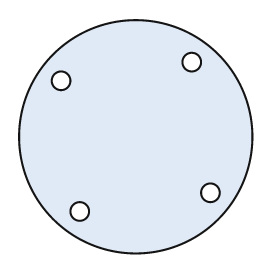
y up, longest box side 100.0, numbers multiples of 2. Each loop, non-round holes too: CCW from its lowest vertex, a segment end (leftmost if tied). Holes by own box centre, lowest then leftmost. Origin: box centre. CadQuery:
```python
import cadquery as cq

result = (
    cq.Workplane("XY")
    .moveTo(0.0, 0.0)
    .circle(50.0)
    .moveTo(-24.0, -32.0)
    .circle(4.0)
    .moveTo(32.0, -24.0)
    .circle(4.0)
    .moveTo(-32.0, 24.0)
    .circle(4.0)
    .moveTo(24.0, 32.0)
    .circle(4.0)
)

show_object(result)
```